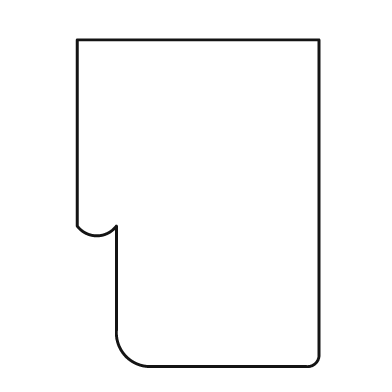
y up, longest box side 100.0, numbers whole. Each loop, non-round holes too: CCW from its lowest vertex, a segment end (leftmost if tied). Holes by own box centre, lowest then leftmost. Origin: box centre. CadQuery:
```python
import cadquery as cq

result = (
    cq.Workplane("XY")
    .moveTo(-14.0, -50.0)
    .lineTo(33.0, -50.0)
    .threePointArc((36.0, -49.0), (37.0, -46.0))
    .lineTo(37.0, 50.0)
    .lineTo(-37.0, 50.0)
    .lineTo(-37.0, -7.0)
    .threePointArc((-31.0, -10.0), (-25.0, -7.0))
    .lineTo(-25.0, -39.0)
    .threePointArc((-22.0, -47.0), (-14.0, -50.0))
    .close()
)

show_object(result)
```